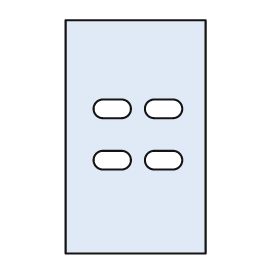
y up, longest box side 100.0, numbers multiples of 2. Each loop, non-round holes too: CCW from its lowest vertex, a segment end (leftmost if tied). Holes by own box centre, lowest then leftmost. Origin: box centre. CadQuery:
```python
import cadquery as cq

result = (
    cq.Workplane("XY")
    .moveTo(-30.0, -50.0)
    .lineTo(30.0, -50.0)
    .lineTo(30.0, 50.0)
    .lineTo(-30.0, 50.0)
    .close()
    .moveTo(-14.0, -14.0)
    .lineTo(-6.0, -14.0)
    .threePointArc((-2.0, -10.0), (-6.0, -6.0))
    .lineTo(-14.0, -6.0)
    .threePointArc((-18.0, -10.0), (-14.0, -14.0))
    .close()
    .moveTo(8.0, -14.0)
    .lineTo(16.0, -14.0)
    .threePointArc((20.0, -10.0), (16.0, -6.0))
    .lineTo(8.0, -6.0)
    .threePointArc((4.0, -10.0), (8.0, -14.0))
    .close()
    .moveTo(-14.0, 8.0)
    .lineTo(-6.0, 8.0)
    .threePointArc((-2.0, 12.0), (-6.0, 16.0))
    .lineTo(-14.0, 16.0)
    .threePointArc((-18.0, 12.0), (-14.0, 8.0))
    .close()
    .moveTo(8.0, 8.0)
    .lineTo(16.0, 8.0)
    .threePointArc((20.0, 12.0), (16.0, 16.0))
    .lineTo(8.0, 16.0)
    .threePointArc((4.0, 12.0), (8.0, 8.0))
    .close()
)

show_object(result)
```